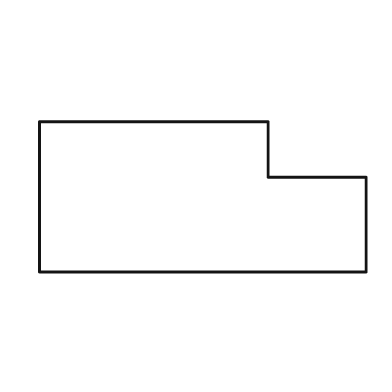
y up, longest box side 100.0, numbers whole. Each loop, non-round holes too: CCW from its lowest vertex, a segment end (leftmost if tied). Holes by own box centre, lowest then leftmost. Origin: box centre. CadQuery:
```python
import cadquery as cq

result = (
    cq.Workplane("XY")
    .moveTo(-50.0, -23.0)
    .lineTo(50.0, -23.0)
    .lineTo(50.0, 6.0)
    .lineTo(20.0, 6.0)
    .lineTo(20.0, 23.0)
    .lineTo(-50.0, 23.0)
    .close()
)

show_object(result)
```